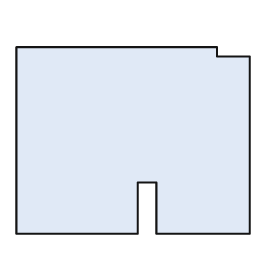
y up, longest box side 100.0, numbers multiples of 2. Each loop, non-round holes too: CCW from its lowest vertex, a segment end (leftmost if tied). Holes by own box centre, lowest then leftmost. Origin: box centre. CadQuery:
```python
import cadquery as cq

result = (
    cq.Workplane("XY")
    .moveTo(-50.0, -40.0)
    .lineTo(2.0, -40.0)
    .lineTo(2.0, -18.0)
    .lineTo(10.0, -18.0)
    .lineTo(10.0, -40.0)
    .lineTo(50.0, -40.0)
    .lineTo(50.0, 36.0)
    .lineTo(36.0, 36.0)
    .lineTo(36.0, 40.0)
    .lineTo(-50.0, 40.0)
    .close()
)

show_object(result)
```